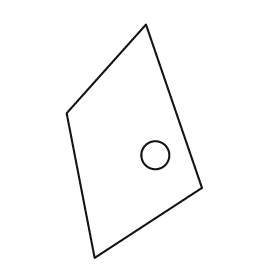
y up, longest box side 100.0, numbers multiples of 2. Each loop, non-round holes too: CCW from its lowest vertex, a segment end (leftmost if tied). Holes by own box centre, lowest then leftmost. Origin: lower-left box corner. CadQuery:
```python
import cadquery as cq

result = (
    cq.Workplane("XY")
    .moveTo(12.0, 0.0)
    .lineTo(58.0, 30.0)
    .lineTo(34.0, 100.0)
    .lineTo(0.0, 62.0)
    .close()
    .moveTo(38.0, 44.0)
    .circle(6.0)
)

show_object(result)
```